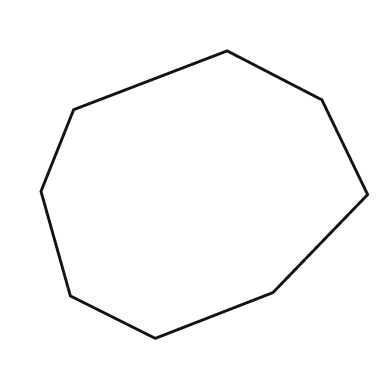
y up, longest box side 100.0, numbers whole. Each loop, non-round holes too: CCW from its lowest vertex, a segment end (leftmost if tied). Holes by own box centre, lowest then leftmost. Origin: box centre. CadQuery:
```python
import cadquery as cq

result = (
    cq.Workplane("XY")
    .moveTo(-15.0, -44.0)
    .lineTo(21.0, -30.0)
    .lineTo(50.0, 0.0)
    .lineTo(36.0, 29.0)
    .lineTo(7.0, 44.0)
    .lineTo(-40.0, 26.0)
    .lineTo(-50.0, 1.0)
    .lineTo(-41.0, -31.0)
    .close()
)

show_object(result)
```